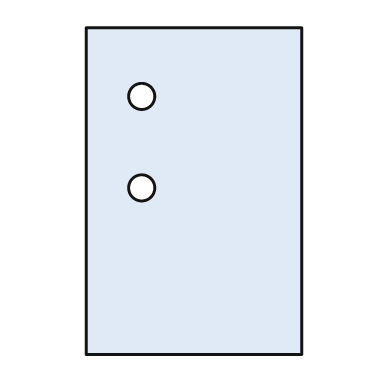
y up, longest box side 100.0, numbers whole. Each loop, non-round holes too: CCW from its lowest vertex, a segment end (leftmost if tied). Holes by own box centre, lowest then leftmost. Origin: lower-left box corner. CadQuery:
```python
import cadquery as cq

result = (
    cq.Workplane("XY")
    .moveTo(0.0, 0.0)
    .lineTo(66.0, 0.0)
    .lineTo(66.0, 100.0)
    .lineTo(0.0, 100.0)
    .close()
    .moveTo(17.0, 51.0)
    .circle(4.0)
    .moveTo(17.0, 79.0)
    .circle(4.0)
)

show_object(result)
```